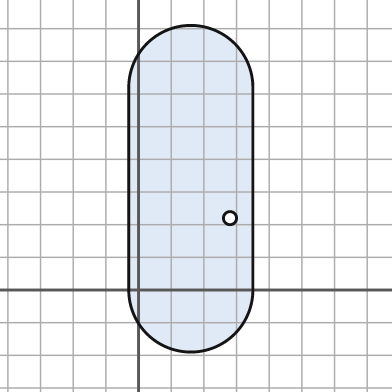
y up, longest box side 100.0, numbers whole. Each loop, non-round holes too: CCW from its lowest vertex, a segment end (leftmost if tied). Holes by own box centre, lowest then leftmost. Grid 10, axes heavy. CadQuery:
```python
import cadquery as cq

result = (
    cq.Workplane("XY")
    .moveTo(-3.0, 0.0)
    .threePointArc((16.0, -19.0), (35.0, 0.0))
    .lineTo(35.0, 62.0)
    .threePointArc((16.0, 81.0), (-3.0, 62.0))
    .close()
    .moveTo(28.0, 22.0)
    .circle(2.0)
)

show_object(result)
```